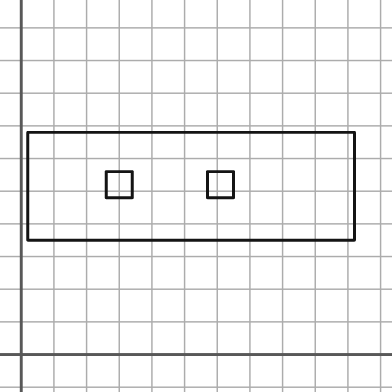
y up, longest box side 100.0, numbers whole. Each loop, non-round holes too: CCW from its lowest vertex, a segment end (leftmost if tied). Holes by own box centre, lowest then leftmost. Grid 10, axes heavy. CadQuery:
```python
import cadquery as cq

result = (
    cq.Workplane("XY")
    .moveTo(2.0, 35.0)
    .lineTo(102.0, 35.0)
    .lineTo(102.0, 68.0)
    .lineTo(2.0, 68.0)
    .close()
    .moveTo(26.0, 48.0)
    .lineTo(34.0, 48.0)
    .lineTo(34.0, 56.0)
    .lineTo(26.0, 56.0)
    .close()
    .moveTo(57.0, 48.0)
    .lineTo(65.0, 48.0)
    .lineTo(65.0, 56.0)
    .lineTo(57.0, 56.0)
    .close()
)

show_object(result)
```